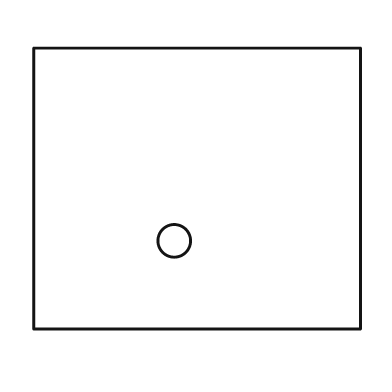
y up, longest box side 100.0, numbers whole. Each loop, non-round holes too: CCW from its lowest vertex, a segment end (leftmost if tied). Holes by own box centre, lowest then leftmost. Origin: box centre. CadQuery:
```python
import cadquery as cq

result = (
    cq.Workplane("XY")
    .moveTo(-50.0, -43.0)
    .lineTo(50.0, -43.0)
    .lineTo(50.0, 43.0)
    .lineTo(-50.0, 43.0)
    .close()
    .moveTo(-7.0, -16.0)
    .circle(5.0)
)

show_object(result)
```